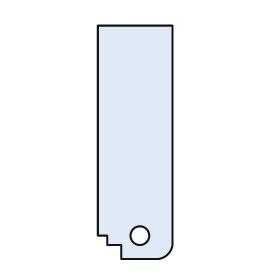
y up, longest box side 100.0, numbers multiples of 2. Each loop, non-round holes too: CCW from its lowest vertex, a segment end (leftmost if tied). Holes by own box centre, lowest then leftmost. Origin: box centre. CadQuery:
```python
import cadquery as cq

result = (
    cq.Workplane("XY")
    .moveTo(-6.0, -50.0)
    .lineTo(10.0, -50.0)
    .threePointArc((14.0, -48.0), (16.0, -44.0))
    .lineTo(16.0, 50.0)
    .lineTo(-16.0, 50.0)
    .lineTo(-16.0, -40.0)
    .lineTo(-12.0, -40.0)
    .lineTo(-12.0, -44.0)
    .lineTo(-6.0, -44.0)
    .close()
    .moveTo(2.0, -40.0)
    .circle(4.0)
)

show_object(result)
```